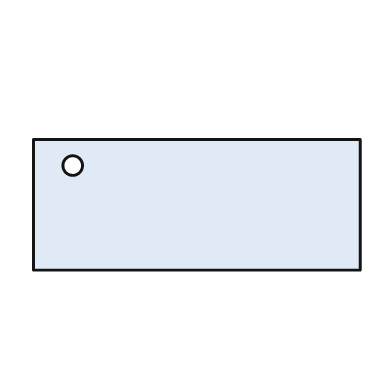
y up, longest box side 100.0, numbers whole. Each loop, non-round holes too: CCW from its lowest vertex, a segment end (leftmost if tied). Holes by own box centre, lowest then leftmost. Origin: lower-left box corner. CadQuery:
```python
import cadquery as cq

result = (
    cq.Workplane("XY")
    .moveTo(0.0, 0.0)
    .lineTo(100.0, 0.0)
    .lineTo(100.0, 40.0)
    .lineTo(0.0, 40.0)
    .close()
    .moveTo(12.0, 32.0)
    .circle(3.0)
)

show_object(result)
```